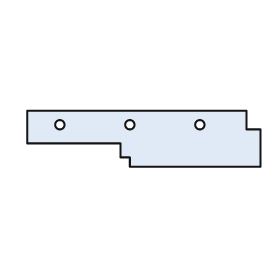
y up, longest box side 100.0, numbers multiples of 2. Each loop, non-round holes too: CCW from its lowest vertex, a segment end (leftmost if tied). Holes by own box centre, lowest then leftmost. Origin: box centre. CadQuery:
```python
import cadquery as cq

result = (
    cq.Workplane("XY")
    .moveTo(-6.0, -12.0)
    .lineTo(50.0, -12.0)
    .lineTo(50.0, 4.0)
    .lineTo(44.0, 4.0)
    .lineTo(44.0, 12.0)
    .lineTo(-50.0, 12.0)
    .lineTo(-50.0, -2.0)
    .lineTo(-10.0, -2.0)
    .lineTo(-10.0, -8.0)
    .lineTo(-6.0, -8.0)
    .close()
    .moveTo(-36.0, 6.0)
    .circle(2.0)
    .moveTo(-6.0, 6.0)
    .circle(2.0)
    .moveTo(24.0, 6.0)
    .circle(2.0)
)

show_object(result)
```